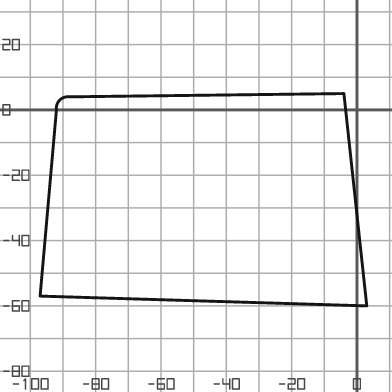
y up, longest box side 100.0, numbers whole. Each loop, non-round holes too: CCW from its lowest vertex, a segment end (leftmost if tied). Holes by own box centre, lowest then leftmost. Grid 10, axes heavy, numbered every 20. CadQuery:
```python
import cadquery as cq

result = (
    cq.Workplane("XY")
    .moveTo(3.0, -60.0)
    .lineTo(-4.0, 5.0)
    .lineTo(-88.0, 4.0)
    .threePointArc((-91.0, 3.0), (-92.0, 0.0))
    .lineTo(-97.0, -57.0)
    .close()
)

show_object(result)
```